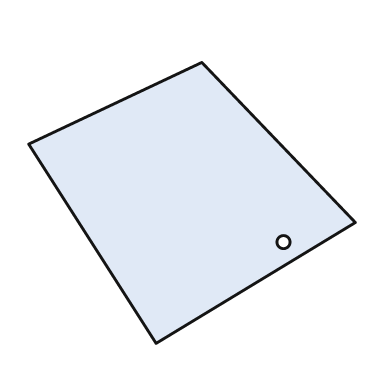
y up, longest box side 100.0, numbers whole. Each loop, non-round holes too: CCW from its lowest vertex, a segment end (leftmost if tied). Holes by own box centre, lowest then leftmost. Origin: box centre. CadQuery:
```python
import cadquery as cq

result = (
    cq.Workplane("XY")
    .moveTo(-11.0, -43.0)
    .lineTo(50.0, -6.0)
    .lineTo(3.0, 43.0)
    .lineTo(-50.0, 18.0)
    .close()
    .moveTo(28.0, -12.0)
    .circle(2.0)
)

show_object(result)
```